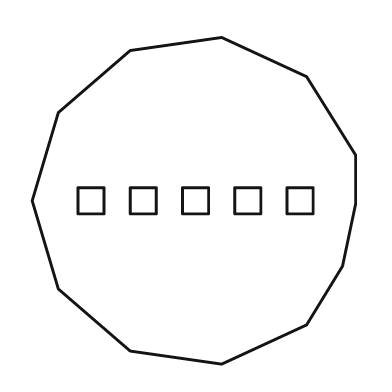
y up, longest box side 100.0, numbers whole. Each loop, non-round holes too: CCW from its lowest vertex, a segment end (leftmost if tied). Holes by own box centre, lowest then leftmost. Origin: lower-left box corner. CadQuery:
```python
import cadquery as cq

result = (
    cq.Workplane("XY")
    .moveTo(58.0, 0.0)
    .lineTo(84.0, 12.0)
    .lineTo(95.0, 30.0)
    .lineTo(99.0, 49.0)
    .lineTo(99.0, 64.0)
    .lineTo(84.0, 88.0)
    .lineTo(58.0, 100.0)
    .lineTo(30.0, 96.0)
    .lineTo(8.0, 77.0)
    .lineTo(0.0, 50.0)
    .lineTo(8.0, 23.0)
    .lineTo(30.0, 4.0)
    .close()
    .moveTo(14.0, 46.0)
    .lineTo(22.0, 46.0)
    .lineTo(22.0, 54.0)
    .lineTo(14.0, 54.0)
    .close()
    .moveTo(30.0, 46.0)
    .lineTo(38.0, 46.0)
    .lineTo(38.0, 54.0)
    .lineTo(30.0, 54.0)
    .close()
    .moveTo(46.0, 46.0)
    .lineTo(54.0, 46.0)
    .lineTo(54.0, 54.0)
    .lineTo(46.0, 54.0)
    .close()
    .moveTo(62.0, 46.0)
    .lineTo(70.0, 46.0)
    .lineTo(70.0, 54.0)
    .lineTo(62.0, 54.0)
    .close()
    .moveTo(78.0, 46.0)
    .lineTo(86.0, 46.0)
    .lineTo(86.0, 54.0)
    .lineTo(78.0, 54.0)
    .close()
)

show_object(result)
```